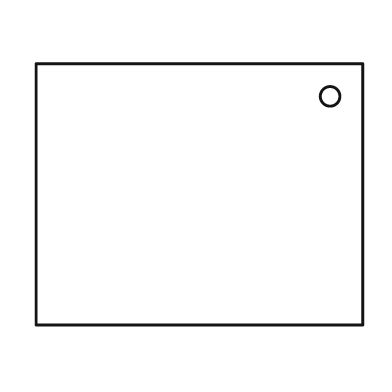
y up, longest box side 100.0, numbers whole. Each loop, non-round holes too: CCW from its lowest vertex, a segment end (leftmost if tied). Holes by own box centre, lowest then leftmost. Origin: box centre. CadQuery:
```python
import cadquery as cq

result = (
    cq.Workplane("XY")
    .moveTo(-50.0, -40.0)
    .lineTo(50.0, -40.0)
    .lineTo(50.0, 40.0)
    .lineTo(-50.0, 40.0)
    .close()
    .moveTo(40.0, 30.0)
    .circle(3.0)
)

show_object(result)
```